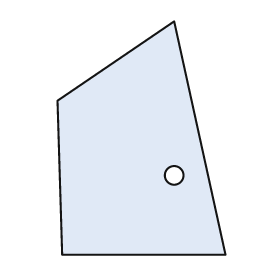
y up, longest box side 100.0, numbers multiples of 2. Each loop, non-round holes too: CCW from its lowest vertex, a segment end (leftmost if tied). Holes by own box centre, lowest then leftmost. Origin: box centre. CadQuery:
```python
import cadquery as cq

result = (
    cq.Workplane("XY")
    .moveTo(-34.0, -50.0)
    .lineTo(36.0, -50.0)
    .lineTo(14.0, 50.0)
    .lineTo(-36.0, 16.0)
    .close()
    .moveTo(14.0, -16.0)
    .circle(4.0)
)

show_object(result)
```